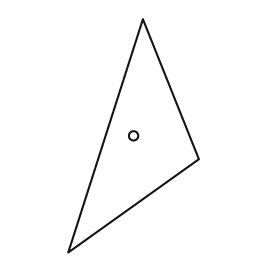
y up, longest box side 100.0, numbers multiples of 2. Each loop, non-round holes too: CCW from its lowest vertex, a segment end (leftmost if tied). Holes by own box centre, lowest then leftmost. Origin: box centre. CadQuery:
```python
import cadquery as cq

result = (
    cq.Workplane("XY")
    .moveTo(-28.0, -50.0)
    .lineTo(28.0, -10.0)
    .lineTo(4.0, 50.0)
    .close()
    .moveTo(0.0, 0.0)
    .circle(2.0)
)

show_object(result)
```